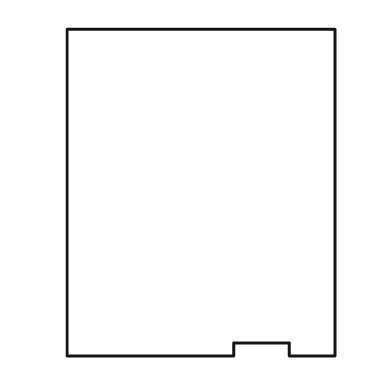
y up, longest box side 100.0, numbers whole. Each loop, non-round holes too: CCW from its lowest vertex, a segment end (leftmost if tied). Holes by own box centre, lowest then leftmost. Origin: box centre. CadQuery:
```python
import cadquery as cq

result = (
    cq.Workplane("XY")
    .moveTo(-41.0, -50.0)
    .lineTo(10.0, -50.0)
    .lineTo(10.0, -46.0)
    .lineTo(27.0, -46.0)
    .lineTo(27.0, -50.0)
    .lineTo(41.0, -50.0)
    .lineTo(41.0, 50.0)
    .lineTo(-41.0, 50.0)
    .close()
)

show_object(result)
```